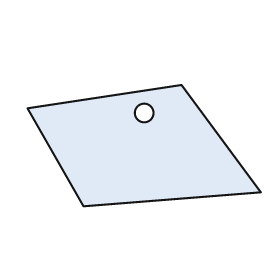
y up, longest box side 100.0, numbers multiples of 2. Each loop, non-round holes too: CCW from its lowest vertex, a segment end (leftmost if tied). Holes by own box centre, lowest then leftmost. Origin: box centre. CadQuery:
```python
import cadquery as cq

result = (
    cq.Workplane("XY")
    .moveTo(-26.0, -26.0)
    .lineTo(50.0, -20.0)
    .lineTo(16.0, 26.0)
    .lineTo(-50.0, 16.0)
    .close()
    .moveTo(0.0, 14.0)
    .circle(4.0)
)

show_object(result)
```